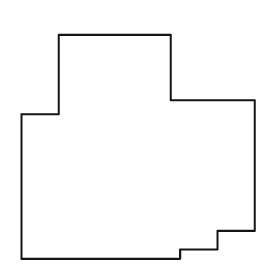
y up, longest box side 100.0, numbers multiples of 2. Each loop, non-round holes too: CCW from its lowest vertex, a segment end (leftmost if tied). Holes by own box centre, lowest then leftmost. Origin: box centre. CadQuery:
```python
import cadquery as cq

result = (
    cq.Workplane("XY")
    .moveTo(-50.0, -48.0)
    .lineTo(18.0, -48.0)
    .lineTo(18.0, -44.0)
    .lineTo(34.0, -44.0)
    .lineTo(34.0, -36.0)
    .lineTo(50.0, -36.0)
    .lineTo(50.0, 20.0)
    .lineTo(14.0, 20.0)
    .lineTo(14.0, 48.0)
    .lineTo(-34.0, 48.0)
    .lineTo(-34.0, 14.0)
    .lineTo(-50.0, 14.0)
    .close()
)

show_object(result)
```